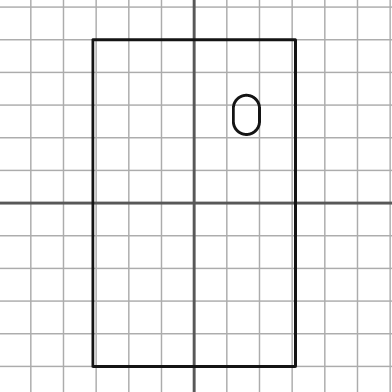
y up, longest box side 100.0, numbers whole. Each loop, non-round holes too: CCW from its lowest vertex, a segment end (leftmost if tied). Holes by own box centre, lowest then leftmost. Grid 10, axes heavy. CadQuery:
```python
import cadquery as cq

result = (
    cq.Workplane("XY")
    .moveTo(-31.0, -50.0)
    .lineTo(31.0, -50.0)
    .lineTo(31.0, 50.0)
    .lineTo(-31.0, 50.0)
    .close()
    .moveTo(12.0, 25.0)
    .threePointArc((16.0, 21.0), (20.0, 25.0))
    .lineTo(20.0, 29.0)
    .threePointArc((16.0, 33.0), (12.0, 29.0))
    .close()
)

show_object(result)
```